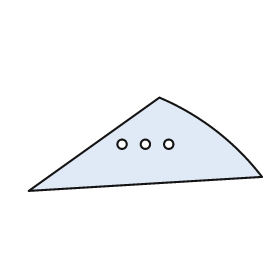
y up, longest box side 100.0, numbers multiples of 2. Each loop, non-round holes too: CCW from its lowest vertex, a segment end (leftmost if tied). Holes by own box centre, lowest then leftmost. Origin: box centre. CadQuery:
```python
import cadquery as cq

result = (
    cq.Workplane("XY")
    .moveTo(-50.0, -20.0)
    .lineTo(50.0, -14.0)
    .threePointArc((30.0, 6.0), (6.0, 20.0))
    .close()
    .moveTo(-10.0, 0.0)
    .circle(2.0)
    .moveTo(0.0, 0.0)
    .circle(2.0)
    .moveTo(10.0, 0.0)
    .circle(2.0)
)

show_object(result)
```